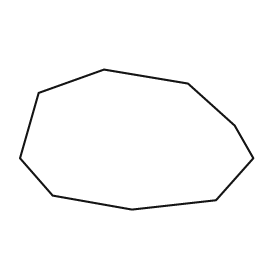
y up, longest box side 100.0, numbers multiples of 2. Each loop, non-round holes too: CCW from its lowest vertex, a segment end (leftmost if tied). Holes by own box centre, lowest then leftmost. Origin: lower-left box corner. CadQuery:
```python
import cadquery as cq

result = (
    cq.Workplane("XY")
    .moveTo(48.0, 0.0)
    .lineTo(84.0, 4.0)
    .lineTo(100.0, 22.0)
    .lineTo(92.0, 36.0)
    .lineTo(72.0, 54.0)
    .lineTo(36.0, 60.0)
    .lineTo(8.0, 50.0)
    .lineTo(0.0, 22.0)
    .lineTo(14.0, 6.0)
    .close()
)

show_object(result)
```